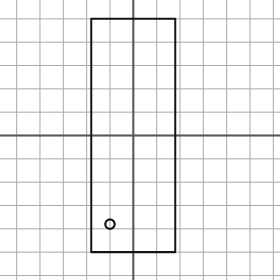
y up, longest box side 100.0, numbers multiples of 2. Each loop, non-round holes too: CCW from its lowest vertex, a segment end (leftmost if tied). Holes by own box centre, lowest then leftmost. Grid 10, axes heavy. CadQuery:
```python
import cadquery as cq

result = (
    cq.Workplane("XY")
    .moveTo(-18.0, -50.0)
    .lineTo(18.0, -50.0)
    .lineTo(18.0, 50.0)
    .lineTo(-18.0, 50.0)
    .close()
    .moveTo(-10.0, -38.0)
    .circle(2.0)
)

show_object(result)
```